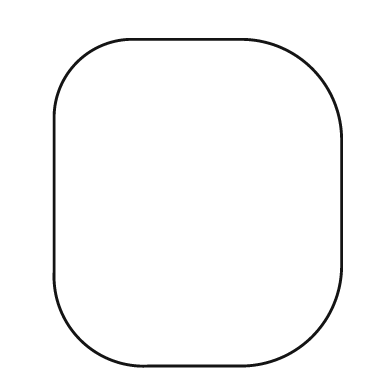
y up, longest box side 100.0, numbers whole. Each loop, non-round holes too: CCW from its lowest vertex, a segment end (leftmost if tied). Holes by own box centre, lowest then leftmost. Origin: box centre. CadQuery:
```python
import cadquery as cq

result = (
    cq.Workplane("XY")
    .moveTo(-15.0, -50.0)
    .lineTo(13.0, -50.0)
    .threePointArc((35.0, -41.0), (44.0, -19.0))
    .lineTo(44.0, 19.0)
    .threePointArc((35.0, 41.0), (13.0, 50.0))
    .lineTo(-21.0, 50.0)
    .threePointArc((-37.0, 43.0), (-44.0, 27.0))
    .lineTo(-44.0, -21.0)
    .threePointArc((-36.0, -42.0), (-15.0, -50.0))
    .close()
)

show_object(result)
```